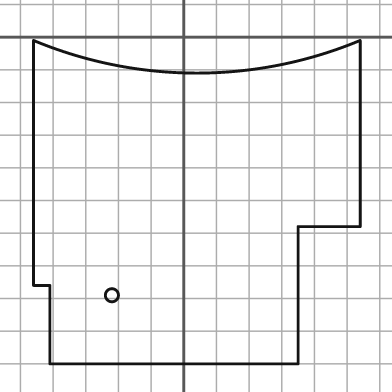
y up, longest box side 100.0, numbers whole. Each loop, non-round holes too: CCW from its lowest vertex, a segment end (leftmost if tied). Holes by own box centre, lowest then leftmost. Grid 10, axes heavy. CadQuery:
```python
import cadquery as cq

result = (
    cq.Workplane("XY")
    .moveTo(-41.0, -100.0)
    .lineTo(35.0, -100.0)
    .lineTo(35.0, -58.0)
    .lineTo(54.0, -58.0)
    .lineTo(54.0, -1.0)
    .threePointArc((4.0, -11.0), (-46.0, -1.0))
    .lineTo(-46.0, -76.0)
    .lineTo(-41.0, -76.0)
    .close()
    .moveTo(-22.0, -79.0)
    .circle(2.0)
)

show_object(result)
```